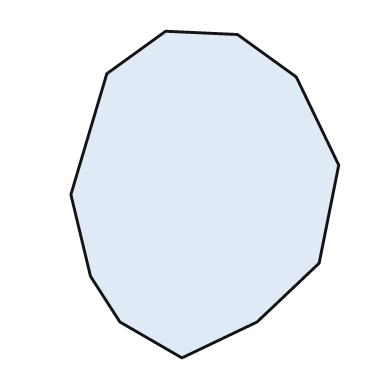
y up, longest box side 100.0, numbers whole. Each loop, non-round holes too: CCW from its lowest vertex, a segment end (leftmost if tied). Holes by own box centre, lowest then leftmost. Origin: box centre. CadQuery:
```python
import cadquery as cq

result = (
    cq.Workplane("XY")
    .moveTo(-7.0, -50.0)
    .lineTo(16.0, -39.0)
    .lineTo(35.0, -21.0)
    .lineTo(41.0, 9.0)
    .lineTo(28.0, 36.0)
    .lineTo(10.0, 49.0)
    .lineTo(-12.0, 50.0)
    .lineTo(-30.0, 37.0)
    .lineTo(-41.0, 0.0)
    .lineTo(-35.0, -25.0)
    .lineTo(-26.0, -39.0)
    .close()
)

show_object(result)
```